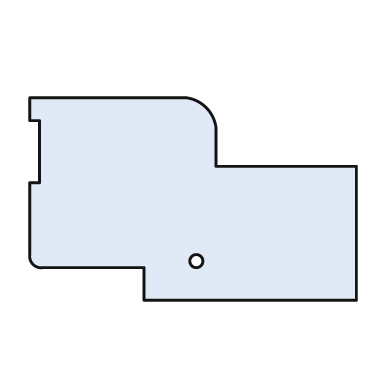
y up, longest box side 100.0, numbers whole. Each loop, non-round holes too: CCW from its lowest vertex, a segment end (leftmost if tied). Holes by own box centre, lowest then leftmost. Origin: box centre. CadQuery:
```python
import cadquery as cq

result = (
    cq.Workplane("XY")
    .moveTo(-15.0, -31.0)
    .lineTo(50.0, -31.0)
    .lineTo(50.0, 10.0)
    .lineTo(7.0, 10.0)
    .lineTo(7.0, 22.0)
    .threePointArc((4.0, 28.0), (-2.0, 31.0))
    .lineTo(-50.0, 31.0)
    .lineTo(-50.0, 24.0)
    .lineTo(-47.0, 24.0)
    .lineTo(-47.0, 5.0)
    .lineTo(-50.0, 5.0)
    .lineTo(-50.0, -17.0)
    .threePointArc((-49.0, -20.0), (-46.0, -21.0))
    .lineTo(-15.0, -21.0)
    .close()
    .moveTo(1.0, -19.0)
    .circle(2.0)
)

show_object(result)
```